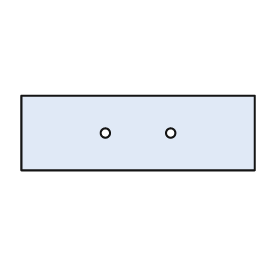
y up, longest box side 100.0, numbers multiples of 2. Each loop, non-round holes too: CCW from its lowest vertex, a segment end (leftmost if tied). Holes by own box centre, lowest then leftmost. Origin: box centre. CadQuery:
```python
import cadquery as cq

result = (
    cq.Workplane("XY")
    .moveTo(-50.0, -16.0)
    .lineTo(50.0, -16.0)
    .lineTo(50.0, 16.0)
    .lineTo(-50.0, 16.0)
    .close()
    .moveTo(-14.0, 0.0)
    .circle(2.0)
    .moveTo(14.0, 0.0)
    .circle(2.0)
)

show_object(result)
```